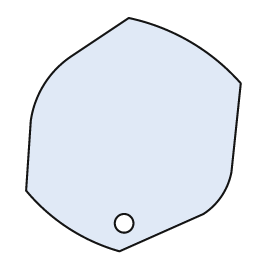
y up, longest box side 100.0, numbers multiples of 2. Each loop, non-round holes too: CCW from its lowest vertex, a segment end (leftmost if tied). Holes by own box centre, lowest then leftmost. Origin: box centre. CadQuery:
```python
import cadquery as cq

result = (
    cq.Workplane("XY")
    .moveTo(-6.0, -50.0)
    .lineTo(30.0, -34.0)
    .threePointArc((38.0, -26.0), (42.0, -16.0))
    .lineTo(46.0, 22.0)
    .threePointArc((24.0, 40.0), (-2.0, 50.0))
    .lineTo(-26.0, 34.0)
    .threePointArc((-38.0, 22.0), (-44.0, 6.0))
    .lineTo(-46.0, -24.0)
    .threePointArc((-28.0, -40.0), (-6.0, -50.0))
    .close()
    .moveTo(-4.0, -38.0)
    .circle(4.0)
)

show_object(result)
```